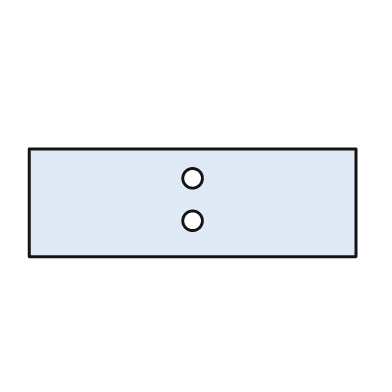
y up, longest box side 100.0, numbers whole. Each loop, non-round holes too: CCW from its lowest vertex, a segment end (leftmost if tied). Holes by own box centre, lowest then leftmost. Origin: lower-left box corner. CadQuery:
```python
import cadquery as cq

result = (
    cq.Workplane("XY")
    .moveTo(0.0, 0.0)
    .lineTo(100.0, 0.0)
    .lineTo(100.0, 33.0)
    .lineTo(0.0, 33.0)
    .close()
    .moveTo(50.0, 11.0)
    .circle(3.0)
    .moveTo(50.0, 24.0)
    .circle(3.0)
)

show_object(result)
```